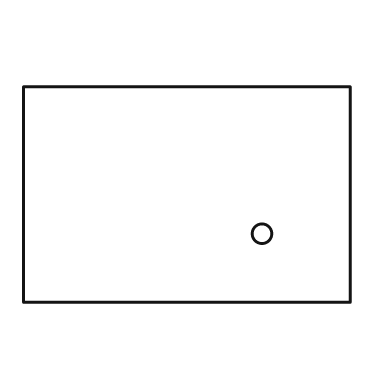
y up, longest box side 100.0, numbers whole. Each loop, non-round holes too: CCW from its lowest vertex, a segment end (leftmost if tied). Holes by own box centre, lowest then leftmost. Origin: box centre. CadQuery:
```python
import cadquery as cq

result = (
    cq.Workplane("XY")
    .moveTo(-50.0, -33.0)
    .lineTo(50.0, -33.0)
    .lineTo(50.0, 33.0)
    .lineTo(-50.0, 33.0)
    .close()
    .moveTo(23.0, -12.0)
    .circle(3.0)
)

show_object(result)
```